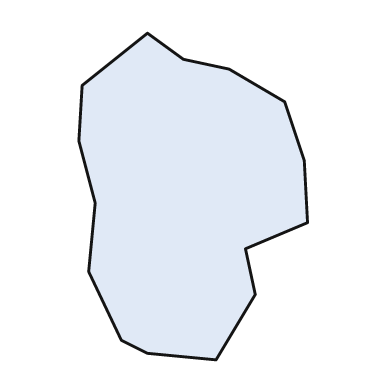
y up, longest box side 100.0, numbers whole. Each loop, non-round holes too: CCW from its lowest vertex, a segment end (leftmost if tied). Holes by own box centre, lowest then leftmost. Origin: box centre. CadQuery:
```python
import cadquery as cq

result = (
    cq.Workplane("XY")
    .moveTo(7.0, -50.0)
    .lineTo(19.0, -30.0)
    .lineTo(16.0, -16.0)
    .lineTo(35.0, -8.0)
    .lineTo(34.0, 11.0)
    .lineTo(28.0, 29.0)
    .lineTo(11.0, 39.0)
    .lineTo(-3.0, 42.0)
    .lineTo(-14.0, 50.0)
    .lineTo(-34.0, 34.0)
    .lineTo(-35.0, 17.0)
    .lineTo(-30.0, -2.0)
    .lineTo(-32.0, -23.0)
    .lineTo(-22.0, -44.0)
    .lineTo(-14.0, -48.0)
    .close()
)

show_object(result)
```